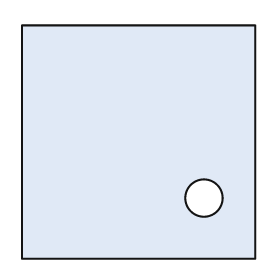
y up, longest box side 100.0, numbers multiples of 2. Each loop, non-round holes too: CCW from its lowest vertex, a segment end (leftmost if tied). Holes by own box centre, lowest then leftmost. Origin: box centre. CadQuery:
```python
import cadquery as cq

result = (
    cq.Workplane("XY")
    .moveTo(-50.0, -50.0)
    .lineTo(50.0, -50.0)
    .lineTo(50.0, 50.0)
    .lineTo(-50.0, 50.0)
    .close()
    .moveTo(28.0, -24.0)
    .circle(8.0)
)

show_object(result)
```